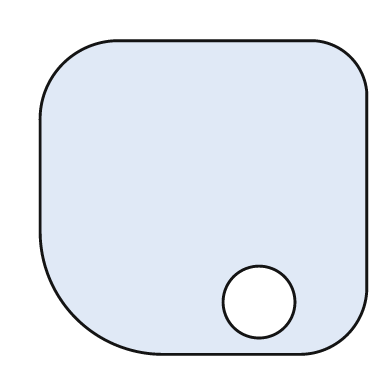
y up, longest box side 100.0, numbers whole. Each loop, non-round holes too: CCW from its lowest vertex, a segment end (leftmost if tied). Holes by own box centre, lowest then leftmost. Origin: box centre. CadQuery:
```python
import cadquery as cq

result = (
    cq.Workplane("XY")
    .moveTo(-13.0, -48.0)
    .lineTo(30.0, -48.0)
    .threePointArc((44.0, -42.0), (50.0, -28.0))
    .lineTo(50.0, 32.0)
    .threePointArc((45.0, 43.0), (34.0, 48.0))
    .lineTo(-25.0, 48.0)
    .threePointArc((-43.0, 41.0), (-50.0, 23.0))
    .lineTo(-50.0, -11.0)
    .threePointArc((-39.0, -37.0), (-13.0, -48.0))
    .close()
    .moveTo(17.0, -32.0)
    .circle(11.0)
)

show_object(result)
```